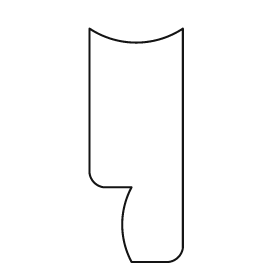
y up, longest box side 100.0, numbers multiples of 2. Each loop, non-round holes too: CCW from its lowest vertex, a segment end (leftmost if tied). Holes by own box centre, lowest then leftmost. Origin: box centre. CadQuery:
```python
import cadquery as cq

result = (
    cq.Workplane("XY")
    .moveTo(-2.0, -50.0)
    .lineTo(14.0, -50.0)
    .threePointArc((18.0, -48.0), (20.0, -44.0))
    .lineTo(20.0, 50.0)
    .threePointArc((0.0, 44.0), (-20.0, 50.0))
    .lineTo(-20.0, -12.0)
    .threePointArc((-18.0, -16.0), (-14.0, -18.0))
    .lineTo(-2.0, -18.0)
    .threePointArc((-6.0, -34.0), (-2.0, -50.0))
    .close()
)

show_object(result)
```